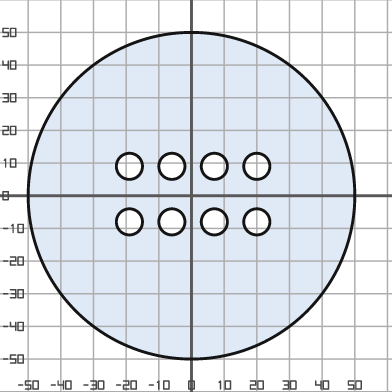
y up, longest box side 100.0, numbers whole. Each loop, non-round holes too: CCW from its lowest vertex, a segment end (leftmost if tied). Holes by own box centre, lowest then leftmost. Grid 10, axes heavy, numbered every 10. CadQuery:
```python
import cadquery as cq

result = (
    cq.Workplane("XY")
    .moveTo(0.0, 0.0)
    .circle(50.0)
    .moveTo(-19.0, -8.0)
    .circle(4.0)
    .moveTo(-6.0, -8.0)
    .circle(4.0)
    .moveTo(7.0, -8.0)
    .circle(4.0)
    .moveTo(20.0, -8.0)
    .circle(4.0)
    .moveTo(-19.0, 9.0)
    .circle(4.0)
    .moveTo(-6.0, 9.0)
    .circle(4.0)
    .moveTo(7.0, 9.0)
    .circle(4.0)
    .moveTo(20.0, 9.0)
    .circle(4.0)
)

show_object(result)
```